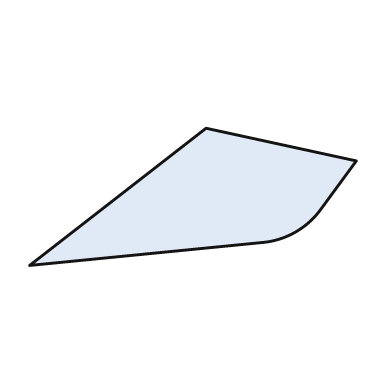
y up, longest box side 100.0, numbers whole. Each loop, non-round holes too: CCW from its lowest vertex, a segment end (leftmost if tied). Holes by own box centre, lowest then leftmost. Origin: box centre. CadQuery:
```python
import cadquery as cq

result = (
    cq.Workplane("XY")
    .moveTo(-50.0, -21.0)
    .lineTo(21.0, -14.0)
    .threePointArc((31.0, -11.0), (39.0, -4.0))
    .lineTo(50.0, 11.0)
    .lineTo(4.0, 21.0)
    .close()
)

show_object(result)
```